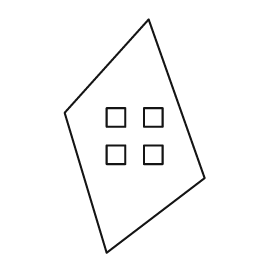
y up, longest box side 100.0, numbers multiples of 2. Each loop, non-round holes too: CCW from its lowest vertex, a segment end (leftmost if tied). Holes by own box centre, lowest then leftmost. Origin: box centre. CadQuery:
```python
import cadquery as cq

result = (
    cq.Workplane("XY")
    .moveTo(-12.0, -50.0)
    .lineTo(30.0, -18.0)
    .lineTo(6.0, 50.0)
    .lineTo(-30.0, 10.0)
    .close()
    .moveTo(-12.0, -12.0)
    .lineTo(-4.0, -12.0)
    .lineTo(-4.0, -4.0)
    .lineTo(-12.0, -4.0)
    .close()
    .moveTo(4.0, -12.0)
    .lineTo(12.0, -12.0)
    .lineTo(12.0, -4.0)
    .lineTo(4.0, -4.0)
    .close()
    .moveTo(-12.0, 4.0)
    .lineTo(-4.0, 4.0)
    .lineTo(-4.0, 12.0)
    .lineTo(-12.0, 12.0)
    .close()
    .moveTo(4.0, 4.0)
    .lineTo(12.0, 4.0)
    .lineTo(12.0, 12.0)
    .lineTo(4.0, 12.0)
    .close()
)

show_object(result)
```